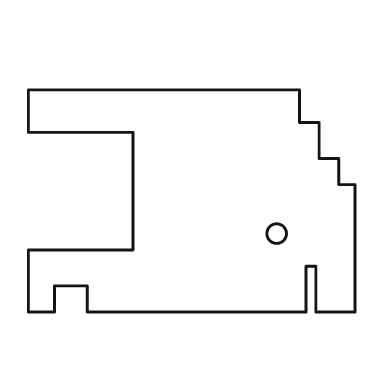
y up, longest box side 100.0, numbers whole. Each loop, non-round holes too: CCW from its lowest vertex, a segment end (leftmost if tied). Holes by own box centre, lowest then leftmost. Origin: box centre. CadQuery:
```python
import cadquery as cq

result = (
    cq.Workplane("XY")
    .moveTo(-50.0, -34.0)
    .lineTo(-42.0, -34.0)
    .lineTo(-42.0, -26.0)
    .lineTo(-32.0, -26.0)
    .lineTo(-32.0, -34.0)
    .lineTo(35.0, -34.0)
    .lineTo(35.0, -20.0)
    .lineTo(38.0, -20.0)
    .lineTo(38.0, -34.0)
    .lineTo(50.0, -34.0)
    .lineTo(50.0, 5.0)
    .lineTo(45.0, 5.0)
    .lineTo(45.0, 13.0)
    .lineTo(39.0, 13.0)
    .lineTo(39.0, 24.0)
    .lineTo(33.0, 24.0)
    .lineTo(33.0, 34.0)
    .lineTo(-50.0, 34.0)
    .lineTo(-50.0, 21.0)
    .lineTo(-18.0, 21.0)
    .lineTo(-18.0, -15.0)
    .lineTo(-50.0, -15.0)
    .close()
    .moveTo(26.0, -10.0)
    .circle(3.0)
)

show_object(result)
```